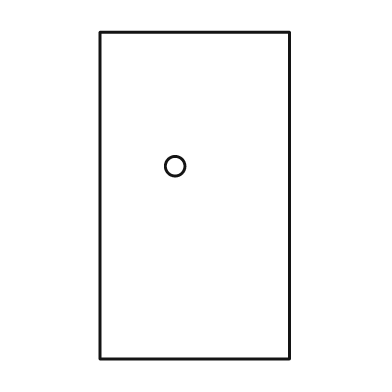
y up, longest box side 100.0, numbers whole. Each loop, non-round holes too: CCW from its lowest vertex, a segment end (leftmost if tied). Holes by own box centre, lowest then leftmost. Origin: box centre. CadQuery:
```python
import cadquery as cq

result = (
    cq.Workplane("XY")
    .moveTo(-29.0, -50.0)
    .lineTo(29.0, -50.0)
    .lineTo(29.0, 50.0)
    .lineTo(-29.0, 50.0)
    .close()
    .moveTo(-6.0, 9.0)
    .circle(3.0)
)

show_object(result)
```